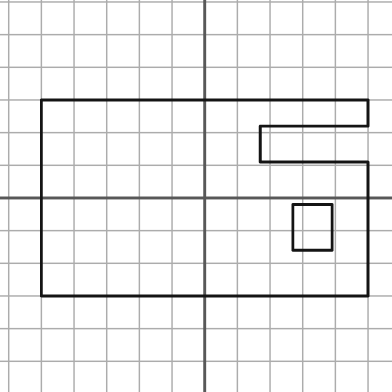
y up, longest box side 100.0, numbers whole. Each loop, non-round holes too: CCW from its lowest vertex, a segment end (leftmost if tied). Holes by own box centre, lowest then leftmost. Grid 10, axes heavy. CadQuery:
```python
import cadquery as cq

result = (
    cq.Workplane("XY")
    .moveTo(-50.0, -30.0)
    .lineTo(50.0, -30.0)
    .lineTo(50.0, 11.0)
    .lineTo(17.0, 11.0)
    .lineTo(17.0, 22.0)
    .lineTo(50.0, 22.0)
    .lineTo(50.0, 30.0)
    .lineTo(-50.0, 30.0)
    .close()
    .moveTo(27.0, -16.0)
    .lineTo(39.0, -16.0)
    .lineTo(39.0, -2.0)
    .lineTo(27.0, -2.0)
    .close()
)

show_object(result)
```